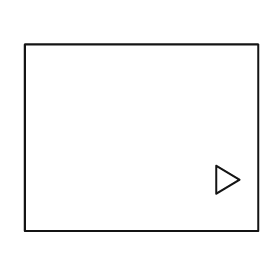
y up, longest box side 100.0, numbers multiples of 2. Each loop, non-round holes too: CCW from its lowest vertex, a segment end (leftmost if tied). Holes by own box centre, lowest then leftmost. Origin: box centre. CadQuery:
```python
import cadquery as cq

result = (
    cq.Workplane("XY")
    .moveTo(-50.0, -40.0)
    .lineTo(50.0, -40.0)
    .lineTo(50.0, 40.0)
    .lineTo(-50.0, 40.0)
    .close()
    .moveTo(32.0, -24.0)
    .lineTo(42.0, -18.0)
    .lineTo(32.0, -12.0)
    .close()
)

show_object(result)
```